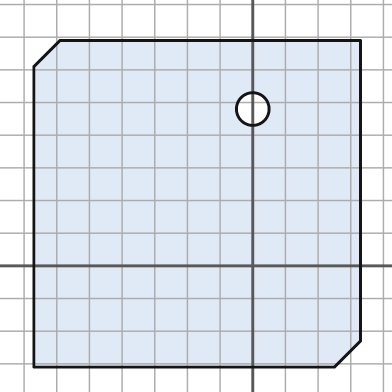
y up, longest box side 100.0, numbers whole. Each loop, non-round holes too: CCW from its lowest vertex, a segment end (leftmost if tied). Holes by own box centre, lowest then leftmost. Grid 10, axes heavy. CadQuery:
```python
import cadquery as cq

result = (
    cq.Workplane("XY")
    .moveTo(-67.0, -31.0)
    .lineTo(25.0, -31.0)
    .lineTo(33.0, -23.0)
    .lineTo(33.0, 69.0)
    .lineTo(-59.0, 69.0)
    .lineTo(-67.0, 61.0)
    .close()
    .moveTo(0.0, 48.0)
    .circle(5.0)
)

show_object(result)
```